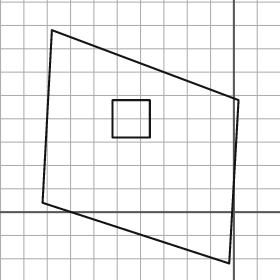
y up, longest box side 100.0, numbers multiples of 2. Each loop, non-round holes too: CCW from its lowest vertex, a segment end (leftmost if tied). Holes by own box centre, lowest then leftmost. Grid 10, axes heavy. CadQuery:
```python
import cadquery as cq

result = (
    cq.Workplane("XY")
    .moveTo(-2.0, -22.0)
    .lineTo(2.0, 48.0)
    .lineTo(-78.0, 78.0)
    .lineTo(-82.0, 4.0)
    .close()
    .moveTo(-52.0, 32.0)
    .lineTo(-36.0, 32.0)
    .lineTo(-36.0, 48.0)
    .lineTo(-52.0, 48.0)
    .close()
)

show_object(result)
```